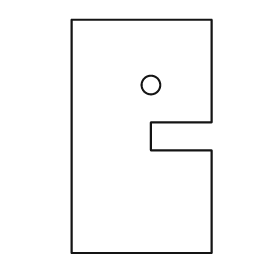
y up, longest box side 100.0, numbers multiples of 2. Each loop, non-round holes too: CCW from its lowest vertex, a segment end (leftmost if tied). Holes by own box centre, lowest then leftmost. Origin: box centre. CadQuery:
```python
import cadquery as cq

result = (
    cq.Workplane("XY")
    .moveTo(-30.0, -50.0)
    .lineTo(30.0, -50.0)
    .lineTo(30.0, -6.0)
    .lineTo(4.0, -6.0)
    .lineTo(4.0, 6.0)
    .lineTo(30.0, 6.0)
    .lineTo(30.0, 50.0)
    .lineTo(-30.0, 50.0)
    .close()
    .moveTo(4.0, 22.0)
    .circle(4.0)
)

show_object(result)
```